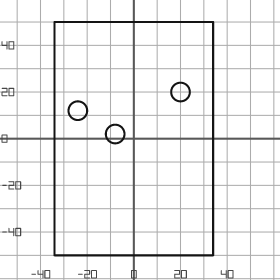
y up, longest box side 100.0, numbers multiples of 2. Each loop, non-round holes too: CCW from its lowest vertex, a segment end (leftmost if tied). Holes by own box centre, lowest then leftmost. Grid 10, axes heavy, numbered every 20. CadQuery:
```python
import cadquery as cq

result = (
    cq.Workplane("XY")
    .moveTo(-34.0, -50.0)
    .lineTo(34.0, -50.0)
    .lineTo(34.0, 50.0)
    .lineTo(-34.0, 50.0)
    .close()
    .moveTo(-8.0, 2.0)
    .circle(4.0)
    .moveTo(-24.0, 12.0)
    .circle(4.0)
    .moveTo(20.0, 20.0)
    .circle(4.0)
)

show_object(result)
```